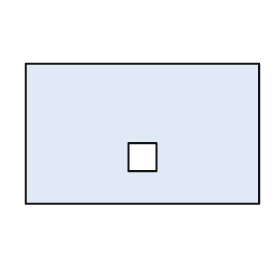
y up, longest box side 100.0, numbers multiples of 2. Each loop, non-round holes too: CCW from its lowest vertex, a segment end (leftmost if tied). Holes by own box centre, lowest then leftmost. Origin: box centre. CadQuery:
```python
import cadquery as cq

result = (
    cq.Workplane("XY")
    .moveTo(-50.0, -30.0)
    .lineTo(50.0, -30.0)
    .lineTo(50.0, 30.0)
    .lineTo(-50.0, 30.0)
    .close()
    .moveTo(-6.0, -16.0)
    .lineTo(6.0, -16.0)
    .lineTo(6.0, -4.0)
    .lineTo(-6.0, -4.0)
    .close()
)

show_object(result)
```